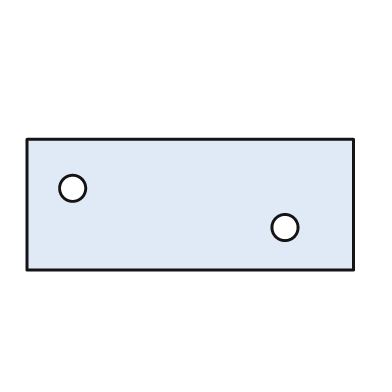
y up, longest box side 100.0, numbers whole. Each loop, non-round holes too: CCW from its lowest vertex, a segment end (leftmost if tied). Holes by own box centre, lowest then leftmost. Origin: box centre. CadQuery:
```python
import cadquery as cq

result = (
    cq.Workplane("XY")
    .moveTo(-50.0, -20.0)
    .lineTo(50.0, -20.0)
    .lineTo(50.0, 20.0)
    .lineTo(-50.0, 20.0)
    .close()
    .moveTo(29.0, -7.0)
    .circle(4.0)
    .moveTo(-36.0, 5.0)
    .circle(4.0)
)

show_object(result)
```